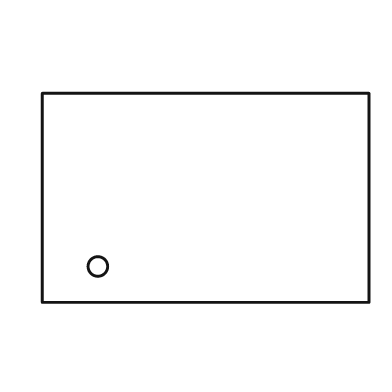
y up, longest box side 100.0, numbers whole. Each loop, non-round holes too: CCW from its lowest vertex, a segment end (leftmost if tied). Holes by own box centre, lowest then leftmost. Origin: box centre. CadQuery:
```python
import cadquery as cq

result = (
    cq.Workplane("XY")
    .moveTo(-50.0, -32.0)
    .lineTo(50.0, -32.0)
    .lineTo(50.0, 32.0)
    .lineTo(-50.0, 32.0)
    .close()
    .moveTo(-33.0, -21.0)
    .circle(3.0)
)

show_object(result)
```